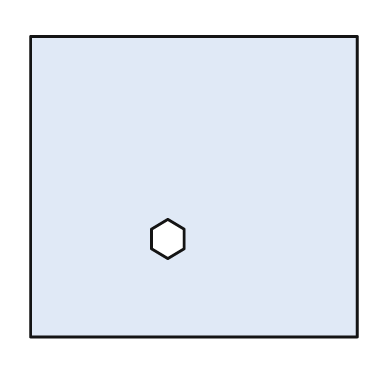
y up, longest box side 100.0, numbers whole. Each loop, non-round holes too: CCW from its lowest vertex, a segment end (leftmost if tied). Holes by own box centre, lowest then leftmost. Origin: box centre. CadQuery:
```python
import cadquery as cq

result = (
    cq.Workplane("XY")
    .moveTo(-50.0, -46.0)
    .lineTo(50.0, -46.0)
    .lineTo(50.0, 46.0)
    .lineTo(-50.0, 46.0)
    .close()
    .moveTo(-8.0, -22.0)
    .lineTo(-3.0, -19.0)
    .lineTo(-3.0, -13.0)
    .lineTo(-8.0, -10.0)
    .lineTo(-13.0, -13.0)
    .lineTo(-13.0, -19.0)
    .close()
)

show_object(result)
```